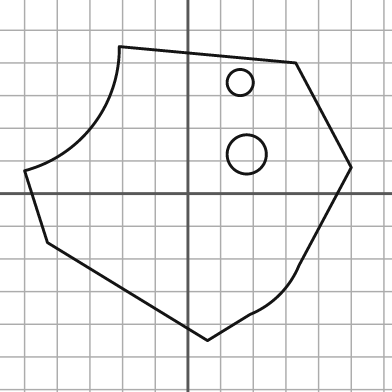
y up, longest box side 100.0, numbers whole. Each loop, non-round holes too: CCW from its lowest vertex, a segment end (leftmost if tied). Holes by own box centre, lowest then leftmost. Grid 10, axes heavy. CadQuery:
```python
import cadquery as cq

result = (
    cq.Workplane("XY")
    .moveTo(6.0, -45.0)
    .lineTo(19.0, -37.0)
    .threePointArc((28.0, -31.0), (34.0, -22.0))
    .lineTo(50.0, 8.0)
    .lineTo(33.0, 40.0)
    .lineTo(-21.0, 45.0)
    .threePointArc((-29.0, 21.0), (-50.0, 7.0))
    .lineTo(-43.0, -15.0)
    .close()
    .moveTo(18.0, 12.0)
    .circle(6.0)
    .moveTo(16.0, 34.0)
    .circle(4.0)
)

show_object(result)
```